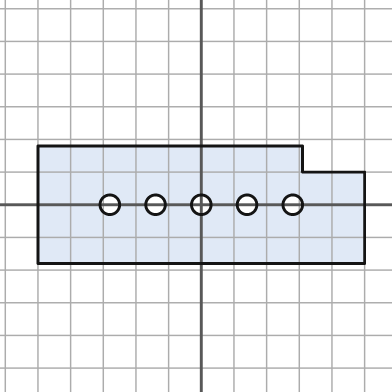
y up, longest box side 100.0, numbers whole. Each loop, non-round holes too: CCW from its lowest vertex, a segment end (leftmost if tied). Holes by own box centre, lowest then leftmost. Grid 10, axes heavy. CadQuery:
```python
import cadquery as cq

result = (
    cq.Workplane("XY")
    .moveTo(-50.0, -18.0)
    .lineTo(50.0, -18.0)
    .lineTo(50.0, 10.0)
    .lineTo(31.0, 10.0)
    .lineTo(31.0, 18.0)
    .lineTo(-50.0, 18.0)
    .close()
    .moveTo(-28.0, 0.0)
    .circle(3.0)
    .moveTo(-14.0, 0.0)
    .circle(3.0)
    .moveTo(0.0, 0.0)
    .circle(3.0)
    .moveTo(14.0, 0.0)
    .circle(3.0)
    .moveTo(28.0, 0.0)
    .circle(3.0)
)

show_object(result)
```